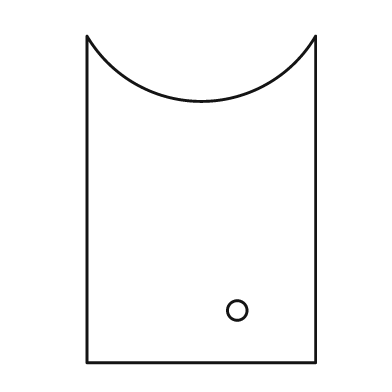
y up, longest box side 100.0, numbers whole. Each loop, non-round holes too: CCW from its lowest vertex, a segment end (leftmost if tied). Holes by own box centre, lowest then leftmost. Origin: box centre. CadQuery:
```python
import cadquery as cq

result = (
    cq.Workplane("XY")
    .moveTo(-35.0, -50.0)
    .lineTo(35.0, -50.0)
    .lineTo(35.0, 50.0)
    .threePointArc((0.0, 30.0), (-35.0, 50.0))
    .close()
    .moveTo(11.0, -34.0)
    .circle(3.0)
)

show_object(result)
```